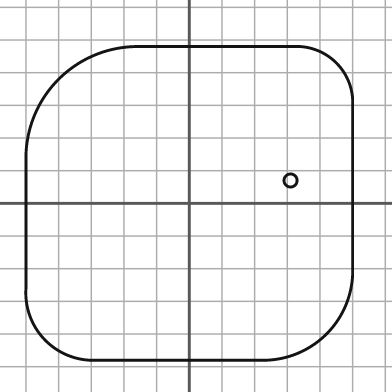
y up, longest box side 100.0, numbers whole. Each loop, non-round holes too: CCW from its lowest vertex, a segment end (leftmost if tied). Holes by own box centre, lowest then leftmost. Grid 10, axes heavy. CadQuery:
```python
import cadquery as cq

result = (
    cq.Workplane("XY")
    .moveTo(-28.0, -48.0)
    .lineTo(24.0, -48.0)
    .threePointArc((42.0, -40.0), (50.0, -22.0))
    .lineTo(50.0, 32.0)
    .threePointArc((45.0, 43.0), (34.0, 48.0))
    .lineTo(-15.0, 48.0)
    .threePointArc((-40.0, 38.0), (-50.0, 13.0))
    .lineTo(-50.0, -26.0)
    .threePointArc((-44.0, -42.0), (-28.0, -48.0))
    .close()
    .moveTo(31.0, 7.0)
    .circle(2.0)
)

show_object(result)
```